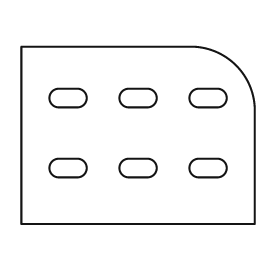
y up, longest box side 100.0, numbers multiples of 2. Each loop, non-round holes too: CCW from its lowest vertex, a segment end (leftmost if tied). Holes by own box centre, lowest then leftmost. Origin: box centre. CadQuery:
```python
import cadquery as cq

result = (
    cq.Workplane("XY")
    .moveTo(-50.0, -38.0)
    .lineTo(50.0, -38.0)
    .lineTo(50.0, 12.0)
    .threePointArc((42.0, 30.0), (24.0, 38.0))
    .lineTo(-50.0, 38.0)
    .close()
    .moveTo(-34.0, -18.0)
    .lineTo(-26.0, -18.0)
    .threePointArc((-22.0, -14.0), (-26.0, -10.0))
    .lineTo(-34.0, -10.0)
    .threePointArc((-38.0, -14.0), (-34.0, -18.0))
    .close()
    .moveTo(-4.0, -18.0)
    .lineTo(4.0, -18.0)
    .threePointArc((8.0, -14.0), (4.0, -10.0))
    .lineTo(-4.0, -10.0)
    .threePointArc((-8.0, -14.0), (-4.0, -18.0))
    .close()
    .moveTo(26.0, -18.0)
    .lineTo(34.0, -18.0)
    .threePointArc((38.0, -14.0), (34.0, -10.0))
    .lineTo(26.0, -10.0)
    .threePointArc((22.0, -14.0), (26.0, -18.0))
    .close()
    .moveTo(-34.0, 12.0)
    .lineTo(-26.0, 12.0)
    .threePointArc((-22.0, 16.0), (-26.0, 20.0))
    .lineTo(-34.0, 20.0)
    .threePointArc((-38.0, 16.0), (-34.0, 12.0))
    .close()
    .moveTo(-4.0, 12.0)
    .lineTo(4.0, 12.0)
    .threePointArc((8.0, 16.0), (4.0, 20.0))
    .lineTo(-4.0, 20.0)
    .threePointArc((-8.0, 16.0), (-4.0, 12.0))
    .close()
    .moveTo(26.0, 12.0)
    .lineTo(34.0, 12.0)
    .threePointArc((38.0, 16.0), (34.0, 20.0))
    .lineTo(26.0, 20.0)
    .threePointArc((22.0, 16.0), (26.0, 12.0))
    .close()
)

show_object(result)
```